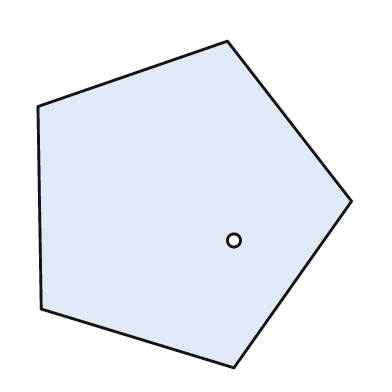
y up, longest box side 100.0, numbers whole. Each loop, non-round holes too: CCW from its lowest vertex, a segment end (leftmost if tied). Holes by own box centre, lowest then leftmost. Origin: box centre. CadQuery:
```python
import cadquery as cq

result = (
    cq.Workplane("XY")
    .moveTo(12.0, -50.0)
    .lineTo(48.0, 1.0)
    .lineTo(10.0, 50.0)
    .lineTo(-48.0, 30.0)
    .lineTo(-47.0, -32.0)
    .close()
    .moveTo(12.0, -11.0)
    .circle(2.0)
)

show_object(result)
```